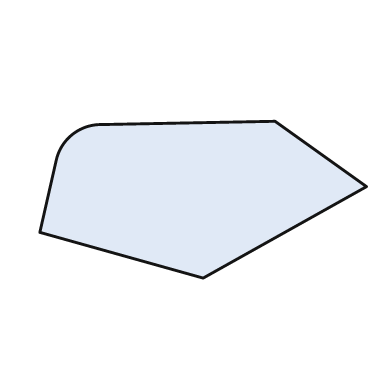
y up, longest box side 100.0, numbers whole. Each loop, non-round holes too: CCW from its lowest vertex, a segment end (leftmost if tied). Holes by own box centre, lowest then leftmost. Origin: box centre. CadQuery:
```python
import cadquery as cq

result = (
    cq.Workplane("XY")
    .moveTo(0.0, -24.0)
    .lineTo(50.0, 4.0)
    .lineTo(22.0, 24.0)
    .lineTo(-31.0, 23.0)
    .threePointArc((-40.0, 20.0), (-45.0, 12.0))
    .lineTo(-50.0, -10.0)
    .close()
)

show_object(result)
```